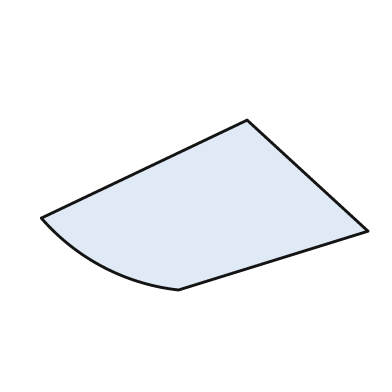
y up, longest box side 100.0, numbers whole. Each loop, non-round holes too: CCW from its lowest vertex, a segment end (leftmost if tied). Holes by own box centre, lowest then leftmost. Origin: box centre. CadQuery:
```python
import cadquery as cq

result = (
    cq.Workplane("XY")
    .moveTo(-8.0, -26.0)
    .lineTo(50.0, -8.0)
    .lineTo(13.0, 26.0)
    .lineTo(-50.0, -4.0)
    .threePointArc((-31.0, -19.0), (-8.0, -26.0))
    .close()
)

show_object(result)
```